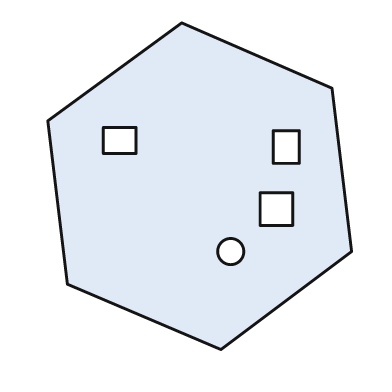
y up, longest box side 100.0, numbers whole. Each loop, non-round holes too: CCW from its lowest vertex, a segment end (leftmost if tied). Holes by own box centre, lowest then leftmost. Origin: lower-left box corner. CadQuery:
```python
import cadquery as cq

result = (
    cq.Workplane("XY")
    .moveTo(53.0, 0.0)
    .lineTo(93.0, 30.0)
    .lineTo(87.0, 80.0)
    .lineTo(41.0, 100.0)
    .lineTo(0.0, 70.0)
    .lineTo(6.0, 20.0)
    .close()
    .moveTo(56.0, 30.0)
    .circle(4.0)
    .moveTo(65.0, 38.0)
    .lineTo(75.0, 38.0)
    .lineTo(75.0, 48.0)
    .lineTo(65.0, 48.0)
    .close()
    .moveTo(69.0, 57.0)
    .lineTo(77.0, 57.0)
    .lineTo(77.0, 67.0)
    .lineTo(69.0, 67.0)
    .close()
    .moveTo(17.0, 60.0)
    .lineTo(27.0, 60.0)
    .lineTo(27.0, 68.0)
    .lineTo(17.0, 68.0)
    .close()
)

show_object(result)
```